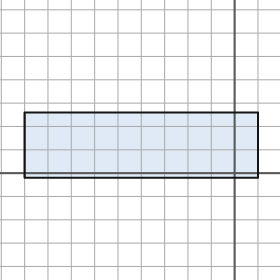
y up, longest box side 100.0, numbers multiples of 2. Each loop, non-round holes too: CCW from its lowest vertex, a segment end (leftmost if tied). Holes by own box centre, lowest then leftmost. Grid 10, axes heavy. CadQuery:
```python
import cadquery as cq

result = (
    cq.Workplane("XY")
    .moveTo(-90.0, -2.0)
    .lineTo(10.0, -2.0)
    .lineTo(10.0, 26.0)
    .lineTo(-90.0, 26.0)
    .close()
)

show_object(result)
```